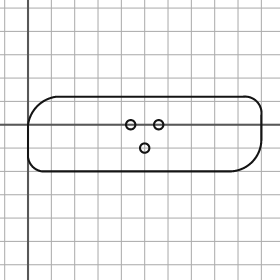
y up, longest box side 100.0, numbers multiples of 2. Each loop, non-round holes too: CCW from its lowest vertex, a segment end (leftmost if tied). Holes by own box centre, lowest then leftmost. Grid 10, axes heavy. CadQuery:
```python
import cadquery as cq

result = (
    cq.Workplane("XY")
    .moveTo(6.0, -20.0)
    .lineTo(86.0, -20.0)
    .threePointArc((96.0, -16.0), (100.0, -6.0))
    .lineTo(100.0, 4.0)
    .threePointArc((98.0, 10.0), (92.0, 12.0))
    .lineTo(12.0, 12.0)
    .threePointArc((4.0, 8.0), (0.0, 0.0))
    .lineTo(0.0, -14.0)
    .threePointArc((2.0, -18.0), (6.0, -20.0))
    .close()
    .moveTo(50.0, -10.0)
    .circle(2.0)
    .moveTo(44.0, 0.0)
    .circle(2.0)
    .moveTo(56.0, 0.0)
    .circle(2.0)
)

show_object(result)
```